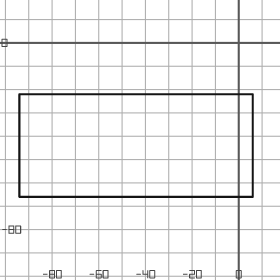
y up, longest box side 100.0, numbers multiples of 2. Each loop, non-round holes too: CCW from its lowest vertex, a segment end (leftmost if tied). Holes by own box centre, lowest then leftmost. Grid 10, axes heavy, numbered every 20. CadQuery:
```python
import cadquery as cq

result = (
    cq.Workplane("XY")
    .moveTo(-94.0, -66.0)
    .lineTo(6.0, -66.0)
    .lineTo(6.0, -22.0)
    .lineTo(-94.0, -22.0)
    .close()
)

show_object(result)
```